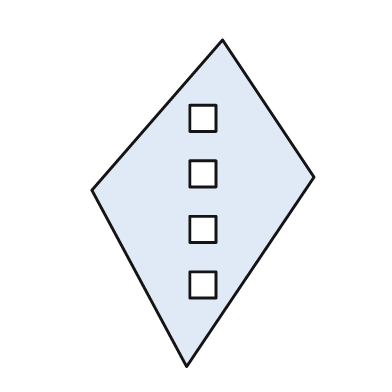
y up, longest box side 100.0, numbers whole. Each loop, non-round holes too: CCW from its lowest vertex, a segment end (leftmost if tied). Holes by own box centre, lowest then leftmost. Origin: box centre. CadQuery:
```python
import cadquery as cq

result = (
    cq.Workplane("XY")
    .moveTo(-5.0, -50.0)
    .lineTo(34.0, 8.0)
    .lineTo(6.0, 50.0)
    .lineTo(-34.0, 4.0)
    .close()
    .moveTo(-4.0, -29.0)
    .lineTo(4.0, -29.0)
    .lineTo(4.0, -21.0)
    .lineTo(-4.0, -21.0)
    .close()
    .moveTo(-4.0, -12.0)
    .lineTo(4.0, -12.0)
    .lineTo(4.0, -4.0)
    .lineTo(-4.0, -4.0)
    .close()
    .moveTo(-4.0, 5.0)
    .lineTo(4.0, 5.0)
    .lineTo(4.0, 13.0)
    .lineTo(-4.0, 13.0)
    .close()
    .moveTo(-4.0, 22.0)
    .lineTo(4.0, 22.0)
    .lineTo(4.0, 30.0)
    .lineTo(-4.0, 30.0)
    .close()
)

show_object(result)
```